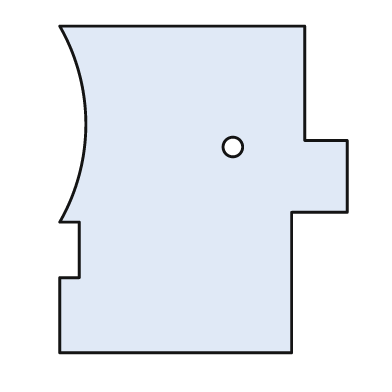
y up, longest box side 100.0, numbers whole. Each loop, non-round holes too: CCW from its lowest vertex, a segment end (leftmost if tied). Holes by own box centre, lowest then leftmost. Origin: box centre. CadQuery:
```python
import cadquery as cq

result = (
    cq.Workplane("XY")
    .moveTo(-44.0, -50.0)
    .lineTo(27.0, -50.0)
    .lineTo(27.0, -7.0)
    .lineTo(44.0, -7.0)
    .lineTo(44.0, 15.0)
    .lineTo(31.0, 15.0)
    .lineTo(31.0, 50.0)
    .lineTo(-44.0, 50.0)
    .threePointArc((-36.0, 20.0), (-44.0, -10.0))
    .lineTo(-38.0, -10.0)
    .lineTo(-38.0, -27.0)
    .lineTo(-44.0, -27.0)
    .close()
    .moveTo(9.0, 13.0)
    .circle(3.0)
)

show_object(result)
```